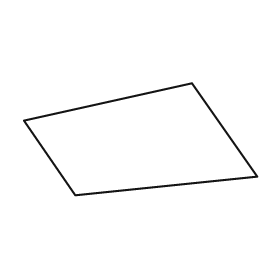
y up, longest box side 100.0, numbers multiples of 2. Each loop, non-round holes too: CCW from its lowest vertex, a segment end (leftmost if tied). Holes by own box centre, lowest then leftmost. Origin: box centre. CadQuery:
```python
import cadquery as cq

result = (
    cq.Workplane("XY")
    .moveTo(-28.0, -24.0)
    .lineTo(50.0, -16.0)
    .lineTo(22.0, 24.0)
    .lineTo(-50.0, 8.0)
    .close()
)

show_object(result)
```